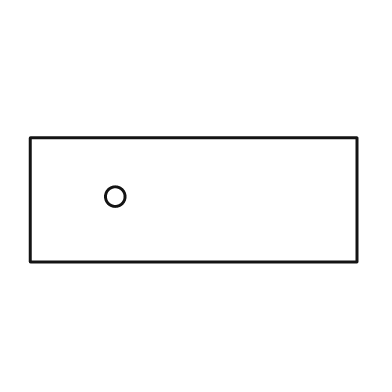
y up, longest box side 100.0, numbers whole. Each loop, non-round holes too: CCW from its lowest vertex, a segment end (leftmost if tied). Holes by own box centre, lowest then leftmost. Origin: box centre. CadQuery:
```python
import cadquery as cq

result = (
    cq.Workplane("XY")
    .moveTo(-50.0, -19.0)
    .lineTo(50.0, -19.0)
    .lineTo(50.0, 19.0)
    .lineTo(-50.0, 19.0)
    .close()
    .moveTo(-24.0, 1.0)
    .circle(3.0)
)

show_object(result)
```